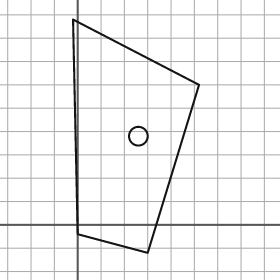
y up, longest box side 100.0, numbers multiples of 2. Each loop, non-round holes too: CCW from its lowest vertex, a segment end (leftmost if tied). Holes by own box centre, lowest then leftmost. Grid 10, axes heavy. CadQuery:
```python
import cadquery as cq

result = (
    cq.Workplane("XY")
    .moveTo(30.0, -12.0)
    .lineTo(52.0, 60.0)
    .lineTo(-2.0, 88.0)
    .lineTo(0.0, -4.0)
    .close()
    .moveTo(26.0, 38.0)
    .circle(4.0)
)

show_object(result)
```